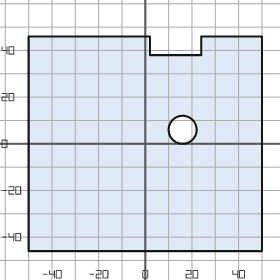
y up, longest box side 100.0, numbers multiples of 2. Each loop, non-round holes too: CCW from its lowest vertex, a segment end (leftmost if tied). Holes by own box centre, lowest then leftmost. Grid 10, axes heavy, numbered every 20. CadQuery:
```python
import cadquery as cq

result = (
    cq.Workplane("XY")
    .moveTo(-50.0, -46.0)
    .lineTo(50.0, -46.0)
    .lineTo(50.0, 46.0)
    .lineTo(24.0, 46.0)
    .lineTo(24.0, 38.0)
    .lineTo(2.0, 38.0)
    .lineTo(2.0, 46.0)
    .lineTo(-50.0, 46.0)
    .close()
    .moveTo(16.0, 6.0)
    .circle(6.0)
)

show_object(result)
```